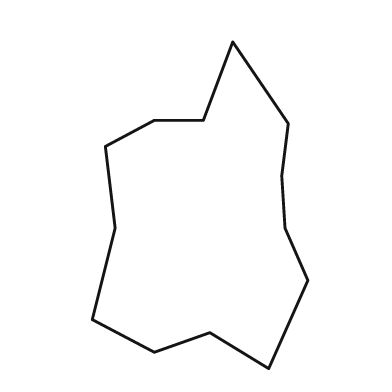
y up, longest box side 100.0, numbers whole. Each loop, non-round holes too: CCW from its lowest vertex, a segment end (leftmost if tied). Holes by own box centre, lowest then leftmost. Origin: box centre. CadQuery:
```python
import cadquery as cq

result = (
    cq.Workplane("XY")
    .moveTo(21.0, -50.0)
    .lineTo(33.0, -23.0)
    .lineTo(26.0, -7.0)
    .lineTo(25.0, 9.0)
    .lineTo(27.0, 25.0)
    .lineTo(10.0, 50.0)
    .lineTo(1.0, 26.0)
    .lineTo(-14.0, 26.0)
    .lineTo(-29.0, 18.0)
    .lineTo(-26.0, -7.0)
    .lineTo(-33.0, -35.0)
    .lineTo(-14.0, -45.0)
    .lineTo(3.0, -39.0)
    .close()
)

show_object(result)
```